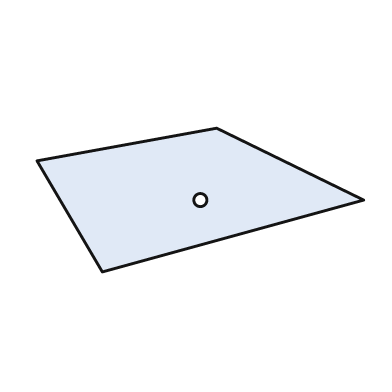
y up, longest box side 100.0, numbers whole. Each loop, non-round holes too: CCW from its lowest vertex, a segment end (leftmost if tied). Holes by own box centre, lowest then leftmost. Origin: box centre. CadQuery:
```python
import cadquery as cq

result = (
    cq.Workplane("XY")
    .moveTo(-30.0, -22.0)
    .lineTo(50.0, 0.0)
    .lineTo(5.0, 22.0)
    .lineTo(-50.0, 12.0)
    .close()
    .moveTo(0.0, 0.0)
    .circle(2.0)
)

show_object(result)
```